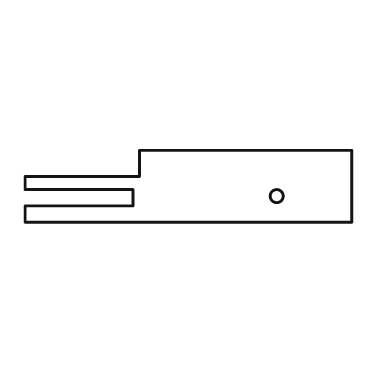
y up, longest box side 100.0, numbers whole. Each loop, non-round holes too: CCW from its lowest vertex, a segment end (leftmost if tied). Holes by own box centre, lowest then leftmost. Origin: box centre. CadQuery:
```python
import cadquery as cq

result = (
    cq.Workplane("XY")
    .moveTo(-50.0, -11.0)
    .lineTo(50.0, -11.0)
    .lineTo(50.0, 11.0)
    .lineTo(-15.0, 11.0)
    .lineTo(-15.0, 3.0)
    .lineTo(-50.0, 3.0)
    .lineTo(-50.0, -1.0)
    .lineTo(-17.0, -1.0)
    .lineTo(-17.0, -6.0)
    .lineTo(-50.0, -6.0)
    .close()
    .moveTo(27.0, -3.0)
    .circle(2.0)
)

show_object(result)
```